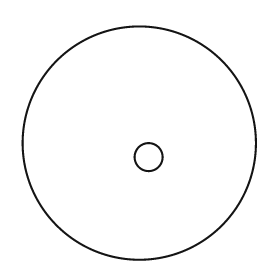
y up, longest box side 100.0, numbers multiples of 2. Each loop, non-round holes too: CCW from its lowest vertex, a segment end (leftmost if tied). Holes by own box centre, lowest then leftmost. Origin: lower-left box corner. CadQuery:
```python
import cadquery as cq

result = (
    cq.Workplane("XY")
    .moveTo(50.0, 50.0)
    .circle(50.0)
    .moveTo(54.0, 44.0)
    .circle(6.0)
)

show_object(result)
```